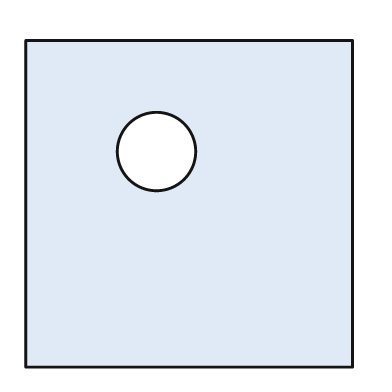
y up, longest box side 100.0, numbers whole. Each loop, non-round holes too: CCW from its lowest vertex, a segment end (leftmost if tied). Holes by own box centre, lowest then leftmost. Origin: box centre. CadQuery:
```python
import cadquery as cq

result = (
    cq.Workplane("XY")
    .moveTo(-50.0, -50.0)
    .lineTo(50.0, -50.0)
    .lineTo(50.0, 50.0)
    .lineTo(-50.0, 50.0)
    .close()
    .moveTo(-10.0, 16.0)
    .circle(12.0)
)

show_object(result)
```